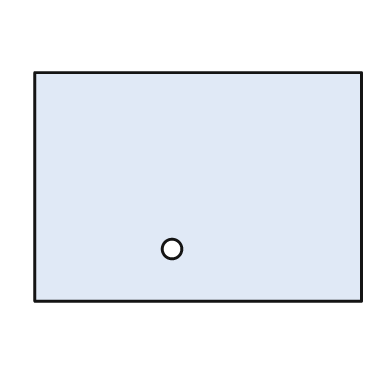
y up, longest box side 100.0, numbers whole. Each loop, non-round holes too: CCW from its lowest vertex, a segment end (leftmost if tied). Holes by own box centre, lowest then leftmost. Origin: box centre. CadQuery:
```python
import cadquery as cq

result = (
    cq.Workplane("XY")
    .moveTo(-50.0, -35.0)
    .lineTo(50.0, -35.0)
    .lineTo(50.0, 35.0)
    .lineTo(-50.0, 35.0)
    .close()
    .moveTo(-8.0, -19.0)
    .circle(3.0)
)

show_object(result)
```